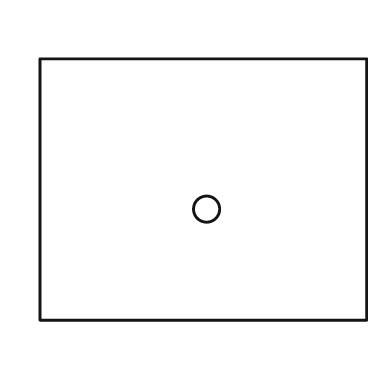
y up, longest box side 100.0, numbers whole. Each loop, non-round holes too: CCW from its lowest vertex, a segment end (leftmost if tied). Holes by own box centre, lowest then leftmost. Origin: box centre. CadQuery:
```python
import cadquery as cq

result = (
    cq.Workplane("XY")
    .moveTo(-50.0, -40.0)
    .lineTo(50.0, -40.0)
    .lineTo(50.0, 40.0)
    .lineTo(-50.0, 40.0)
    .close()
    .moveTo(1.0, -6.0)
    .circle(4.0)
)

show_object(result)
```